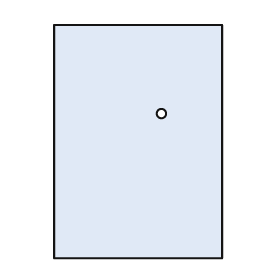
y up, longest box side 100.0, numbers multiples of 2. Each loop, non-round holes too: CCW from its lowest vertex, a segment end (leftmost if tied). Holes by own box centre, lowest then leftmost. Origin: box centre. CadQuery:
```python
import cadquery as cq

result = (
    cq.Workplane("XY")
    .moveTo(-36.0, -50.0)
    .lineTo(36.0, -50.0)
    .lineTo(36.0, 50.0)
    .lineTo(-36.0, 50.0)
    .close()
    .moveTo(10.0, 12.0)
    .circle(2.0)
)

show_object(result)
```